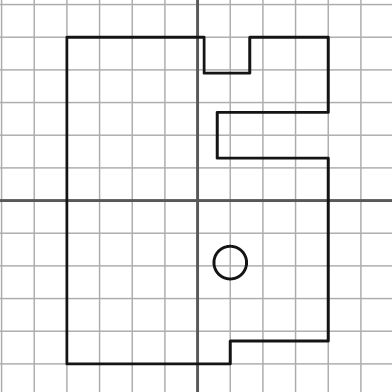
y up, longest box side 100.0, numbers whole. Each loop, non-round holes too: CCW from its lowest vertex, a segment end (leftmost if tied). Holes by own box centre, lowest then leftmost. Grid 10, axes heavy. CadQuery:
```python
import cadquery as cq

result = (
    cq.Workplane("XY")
    .moveTo(-40.0, -50.0)
    .lineTo(10.0, -50.0)
    .lineTo(10.0, -43.0)
    .lineTo(40.0, -43.0)
    .lineTo(40.0, 13.0)
    .lineTo(6.0, 13.0)
    .lineTo(6.0, 27.0)
    .lineTo(40.0, 27.0)
    .lineTo(40.0, 50.0)
    .lineTo(16.0, 50.0)
    .lineTo(16.0, 39.0)
    .lineTo(2.0, 39.0)
    .lineTo(2.0, 50.0)
    .lineTo(-40.0, 50.0)
    .close()
    .moveTo(10.0, -19.0)
    .circle(5.0)
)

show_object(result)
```